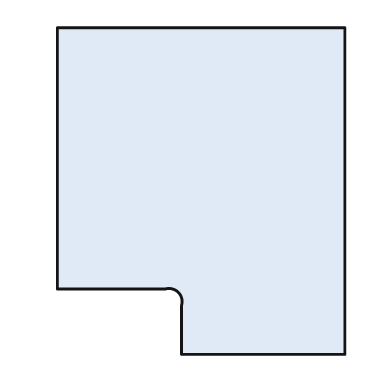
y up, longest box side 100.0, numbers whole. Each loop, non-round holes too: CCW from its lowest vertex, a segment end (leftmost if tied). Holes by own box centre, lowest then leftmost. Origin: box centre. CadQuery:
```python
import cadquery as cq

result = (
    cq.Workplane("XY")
    .moveTo(-6.0, -50.0)
    .lineTo(44.0, -50.0)
    .lineTo(44.0, 50.0)
    .lineTo(-44.0, 50.0)
    .lineTo(-44.0, -30.0)
    .lineTo(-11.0, -30.0)
    .threePointArc((-7.0, -31.0), (-6.0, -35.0))
    .close()
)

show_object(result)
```